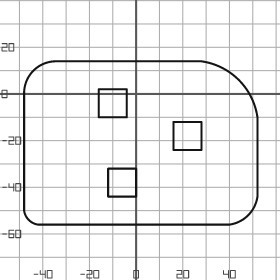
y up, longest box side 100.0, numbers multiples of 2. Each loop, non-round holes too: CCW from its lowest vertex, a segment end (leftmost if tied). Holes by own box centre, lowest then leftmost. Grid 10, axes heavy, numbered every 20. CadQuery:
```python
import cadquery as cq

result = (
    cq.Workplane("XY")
    .moveTo(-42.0, -56.0)
    .lineTo(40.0, -56.0)
    .threePointArc((48.0, -52.0), (52.0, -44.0))
    .lineTo(52.0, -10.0)
    .threePointArc((44.0, 6.0), (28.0, 14.0))
    .lineTo(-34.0, 14.0)
    .threePointArc((-44.0, 10.0), (-48.0, 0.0))
    .lineTo(-48.0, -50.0)
    .threePointArc((-46.0, -54.0), (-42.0, -56.0))
    .close()
    .moveTo(-12.0, -44.0)
    .lineTo(0.0, -44.0)
    .lineTo(0.0, -32.0)
    .lineTo(-12.0, -32.0)
    .close()
    .moveTo(16.0, -24.0)
    .lineTo(28.0, -24.0)
    .lineTo(28.0, -12.0)
    .lineTo(16.0, -12.0)
    .close()
    .moveTo(-16.0, -10.0)
    .lineTo(-4.0, -10.0)
    .lineTo(-4.0, 2.0)
    .lineTo(-16.0, 2.0)
    .close()
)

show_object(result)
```